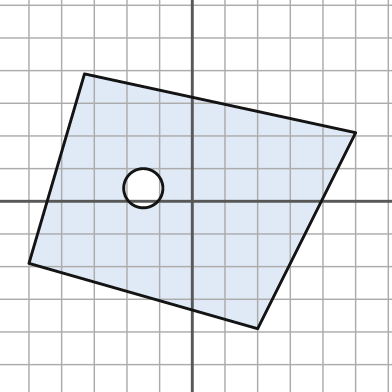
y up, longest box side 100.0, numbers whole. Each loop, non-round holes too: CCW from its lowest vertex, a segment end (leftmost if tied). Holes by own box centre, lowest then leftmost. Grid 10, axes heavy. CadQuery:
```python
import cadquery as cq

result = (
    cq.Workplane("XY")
    .moveTo(20.0, -39.0)
    .lineTo(50.0, 21.0)
    .lineTo(-33.0, 39.0)
    .lineTo(-50.0, -19.0)
    .close()
    .moveTo(-15.0, 4.0)
    .circle(6.0)
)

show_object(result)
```